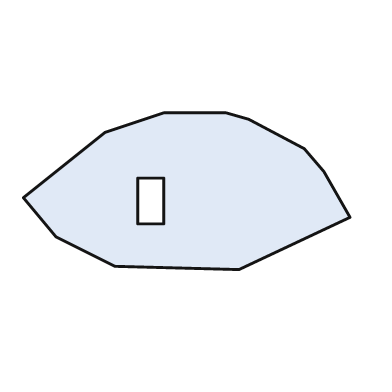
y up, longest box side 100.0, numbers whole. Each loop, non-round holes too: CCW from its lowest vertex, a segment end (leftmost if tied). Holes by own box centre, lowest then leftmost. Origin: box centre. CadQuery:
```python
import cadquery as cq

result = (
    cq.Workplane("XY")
    .moveTo(16.0, -24.0)
    .lineTo(50.0, -8.0)
    .lineTo(42.0, 6.0)
    .lineTo(36.0, 13.0)
    .lineTo(19.0, 22.0)
    .lineTo(12.0, 24.0)
    .lineTo(-7.0, 24.0)
    .lineTo(-25.0, 18.0)
    .lineTo(-50.0, -2.0)
    .lineTo(-40.0, -14.0)
    .lineTo(-22.0, -23.0)
    .close()
    .moveTo(-15.0, -10.0)
    .lineTo(-7.0, -10.0)
    .lineTo(-7.0, 4.0)
    .lineTo(-15.0, 4.0)
    .close()
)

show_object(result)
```